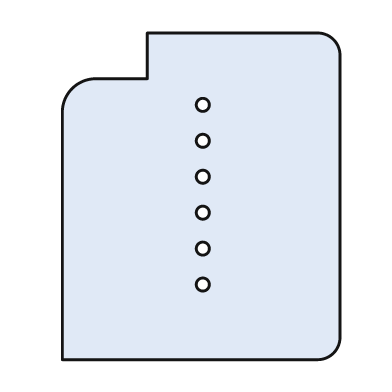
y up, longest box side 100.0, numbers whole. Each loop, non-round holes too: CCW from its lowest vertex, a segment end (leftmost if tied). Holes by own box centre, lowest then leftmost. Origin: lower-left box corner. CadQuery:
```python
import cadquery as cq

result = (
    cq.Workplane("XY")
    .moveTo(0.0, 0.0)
    .lineTo(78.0, 0.0)
    .threePointArc((83.0, 2.0), (85.0, 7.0))
    .lineTo(85.0, 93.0)
    .threePointArc((83.0, 98.0), (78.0, 100.0))
    .lineTo(26.0, 100.0)
    .lineTo(26.0, 86.0)
    .lineTo(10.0, 86.0)
    .threePointArc((3.0, 83.0), (0.0, 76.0))
    .close()
    .moveTo(43.0, 23.0)
    .circle(2.0)
    .moveTo(43.0, 34.0)
    .circle(2.0)
    .moveTo(43.0, 45.0)
    .circle(2.0)
    .moveTo(43.0, 56.0)
    .circle(2.0)
    .moveTo(43.0, 67.0)
    .circle(2.0)
    .moveTo(43.0, 78.0)
    .circle(2.0)
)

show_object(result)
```